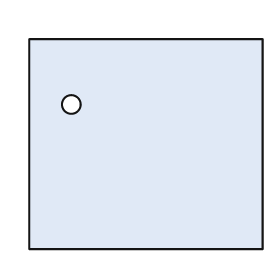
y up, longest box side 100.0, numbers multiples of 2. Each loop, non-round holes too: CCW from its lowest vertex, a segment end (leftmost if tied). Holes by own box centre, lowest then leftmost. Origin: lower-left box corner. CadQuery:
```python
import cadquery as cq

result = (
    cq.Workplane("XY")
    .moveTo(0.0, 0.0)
    .lineTo(100.0, 0.0)
    .lineTo(100.0, 90.0)
    .lineTo(0.0, 90.0)
    .close()
    .moveTo(18.0, 62.0)
    .circle(4.0)
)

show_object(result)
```